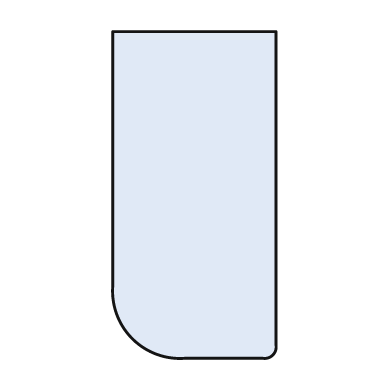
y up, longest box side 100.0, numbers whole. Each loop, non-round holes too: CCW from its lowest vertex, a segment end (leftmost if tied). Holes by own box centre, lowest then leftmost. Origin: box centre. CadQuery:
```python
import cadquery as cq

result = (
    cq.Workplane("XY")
    .moveTo(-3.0, -50.0)
    .lineTo(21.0, -50.0)
    .threePointArc((24.0, -49.0), (25.0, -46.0))
    .lineTo(25.0, 50.0)
    .lineTo(-25.0, 50.0)
    .lineTo(-25.0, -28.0)
    .threePointArc((-19.0, -44.0), (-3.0, -50.0))
    .close()
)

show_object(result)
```